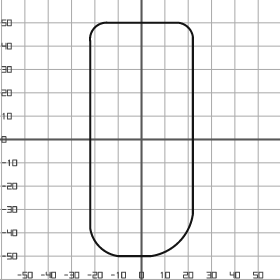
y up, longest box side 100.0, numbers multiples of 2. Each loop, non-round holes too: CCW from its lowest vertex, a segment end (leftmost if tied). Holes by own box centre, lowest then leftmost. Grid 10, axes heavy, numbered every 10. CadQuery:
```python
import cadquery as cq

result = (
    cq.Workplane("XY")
    .moveTo(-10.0, -50.0)
    .lineTo(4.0, -50.0)
    .threePointArc((16.0, -44.0), (22.0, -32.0))
    .lineTo(22.0, 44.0)
    .threePointArc((20.0, 48.0), (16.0, 50.0))
    .lineTo(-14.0, 50.0)
    .threePointArc((-20.0, 48.0), (-22.0, 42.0))
    .lineTo(-22.0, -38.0)
    .threePointArc((-18.0, -46.0), (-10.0, -50.0))
    .close()
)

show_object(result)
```